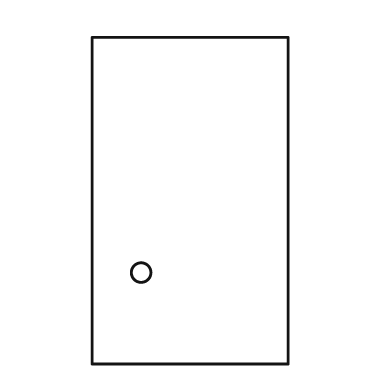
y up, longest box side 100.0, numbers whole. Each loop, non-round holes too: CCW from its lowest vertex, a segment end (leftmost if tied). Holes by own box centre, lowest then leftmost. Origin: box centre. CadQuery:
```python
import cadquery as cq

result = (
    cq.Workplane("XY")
    .moveTo(-30.0, -50.0)
    .lineTo(30.0, -50.0)
    .lineTo(30.0, 50.0)
    .lineTo(-30.0, 50.0)
    .close()
    .moveTo(-15.0, -22.0)
    .circle(3.0)
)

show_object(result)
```